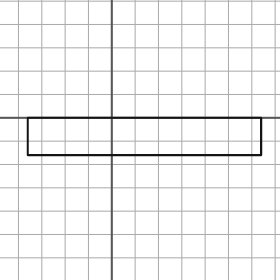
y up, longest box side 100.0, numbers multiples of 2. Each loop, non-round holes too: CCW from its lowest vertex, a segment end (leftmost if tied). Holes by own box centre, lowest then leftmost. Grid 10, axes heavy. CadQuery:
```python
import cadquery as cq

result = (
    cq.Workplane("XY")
    .moveTo(-36.0, -16.0)
    .lineTo(64.0, -16.0)
    .lineTo(64.0, 0.0)
    .lineTo(-36.0, 0.0)
    .close()
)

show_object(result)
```